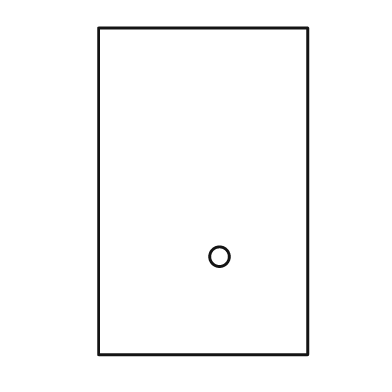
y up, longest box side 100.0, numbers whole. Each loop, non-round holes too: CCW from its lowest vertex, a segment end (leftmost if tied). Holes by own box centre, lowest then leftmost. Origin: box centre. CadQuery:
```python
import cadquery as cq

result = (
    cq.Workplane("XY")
    .moveTo(-32.0, -50.0)
    .lineTo(32.0, -50.0)
    .lineTo(32.0, 50.0)
    .lineTo(-32.0, 50.0)
    .close()
    .moveTo(5.0, -20.0)
    .circle(3.0)
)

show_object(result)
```